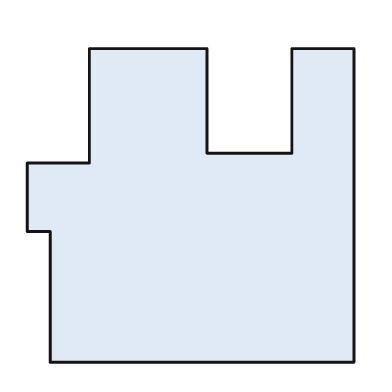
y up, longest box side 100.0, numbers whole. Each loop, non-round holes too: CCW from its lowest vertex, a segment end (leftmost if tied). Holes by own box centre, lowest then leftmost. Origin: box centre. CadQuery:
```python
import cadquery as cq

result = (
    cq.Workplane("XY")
    .moveTo(-43.0, -48.0)
    .lineTo(50.0, -48.0)
    .lineTo(50.0, 48.0)
    .lineTo(31.0, 48.0)
    .lineTo(31.0, 16.0)
    .lineTo(5.0, 16.0)
    .lineTo(5.0, 48.0)
    .lineTo(-31.0, 48.0)
    .lineTo(-31.0, 13.0)
    .lineTo(-50.0, 13.0)
    .lineTo(-50.0, -8.0)
    .lineTo(-43.0, -8.0)
    .close()
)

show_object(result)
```